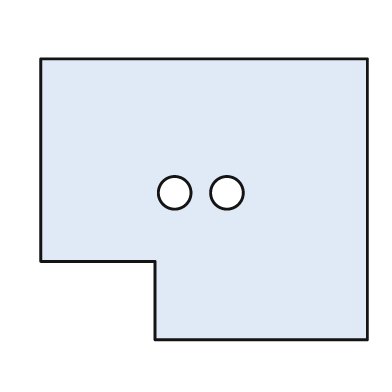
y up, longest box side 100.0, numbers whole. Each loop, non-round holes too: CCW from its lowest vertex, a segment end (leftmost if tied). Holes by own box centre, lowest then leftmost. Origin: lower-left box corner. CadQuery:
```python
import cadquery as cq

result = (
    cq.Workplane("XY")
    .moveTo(35.0, 0.0)
    .lineTo(100.0, 0.0)
    .lineTo(100.0, 86.0)
    .lineTo(0.0, 86.0)
    .lineTo(0.0, 24.0)
    .lineTo(35.0, 24.0)
    .close()
    .moveTo(41.0, 45.0)
    .circle(5.0)
    .moveTo(57.0, 45.0)
    .circle(5.0)
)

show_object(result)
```